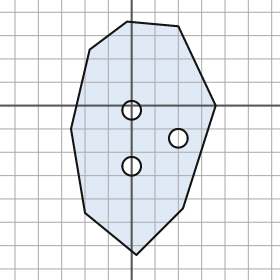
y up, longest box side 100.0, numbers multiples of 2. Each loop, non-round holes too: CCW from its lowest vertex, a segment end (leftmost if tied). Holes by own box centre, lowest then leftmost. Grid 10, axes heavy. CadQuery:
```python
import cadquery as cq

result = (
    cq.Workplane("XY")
    .moveTo(2.0, -64.0)
    .lineTo(22.0, -44.0)
    .lineTo(36.0, 0.0)
    .lineTo(20.0, 34.0)
    .lineTo(-2.0, 36.0)
    .lineTo(-18.0, 24.0)
    .lineTo(-26.0, -10.0)
    .lineTo(-20.0, -46.0)
    .close()
    .moveTo(0.0, -26.0)
    .circle(4.0)
    .moveTo(20.0, -14.0)
    .circle(4.0)
    .moveTo(0.0, -2.0)
    .circle(4.0)
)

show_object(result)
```